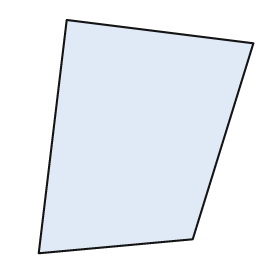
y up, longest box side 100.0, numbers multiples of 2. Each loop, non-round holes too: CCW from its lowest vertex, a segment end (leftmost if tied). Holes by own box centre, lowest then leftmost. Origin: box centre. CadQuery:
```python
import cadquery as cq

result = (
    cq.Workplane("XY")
    .moveTo(-46.0, -50.0)
    .lineTo(20.0, -44.0)
    .lineTo(46.0, 40.0)
    .lineTo(-34.0, 50.0)
    .close()
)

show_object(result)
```